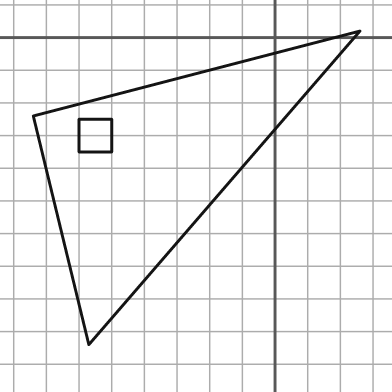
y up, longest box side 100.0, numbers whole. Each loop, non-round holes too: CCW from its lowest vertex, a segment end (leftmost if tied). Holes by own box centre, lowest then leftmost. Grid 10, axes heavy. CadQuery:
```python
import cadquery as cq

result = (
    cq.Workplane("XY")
    .moveTo(-57.0, -94.0)
    .lineTo(26.0, 2.0)
    .lineTo(-74.0, -24.0)
    .close()
    .moveTo(-60.0, -35.0)
    .lineTo(-50.0, -35.0)
    .lineTo(-50.0, -25.0)
    .lineTo(-60.0, -25.0)
    .close()
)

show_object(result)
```